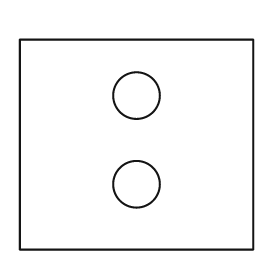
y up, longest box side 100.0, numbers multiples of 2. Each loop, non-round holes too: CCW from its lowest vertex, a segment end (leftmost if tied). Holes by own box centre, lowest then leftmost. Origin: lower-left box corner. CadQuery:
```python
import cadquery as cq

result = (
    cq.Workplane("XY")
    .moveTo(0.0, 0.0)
    .lineTo(100.0, 0.0)
    .lineTo(100.0, 90.0)
    .lineTo(0.0, 90.0)
    .close()
    .moveTo(50.0, 28.0)
    .circle(10.0)
    .moveTo(50.0, 66.0)
    .circle(10.0)
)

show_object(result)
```